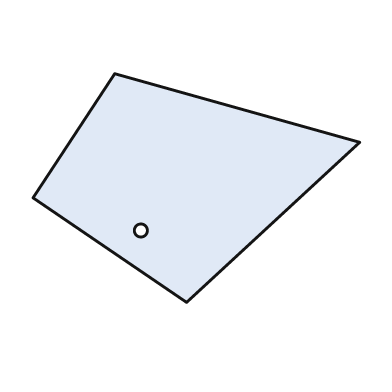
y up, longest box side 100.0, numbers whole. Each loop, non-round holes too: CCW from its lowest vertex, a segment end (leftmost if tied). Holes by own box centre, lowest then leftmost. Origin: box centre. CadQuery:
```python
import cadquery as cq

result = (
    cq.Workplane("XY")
    .moveTo(-3.0, -35.0)
    .lineTo(50.0, 14.0)
    .lineTo(-25.0, 35.0)
    .lineTo(-50.0, -3.0)
    .close()
    .moveTo(-17.0, -13.0)
    .circle(2.0)
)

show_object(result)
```